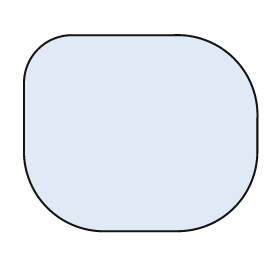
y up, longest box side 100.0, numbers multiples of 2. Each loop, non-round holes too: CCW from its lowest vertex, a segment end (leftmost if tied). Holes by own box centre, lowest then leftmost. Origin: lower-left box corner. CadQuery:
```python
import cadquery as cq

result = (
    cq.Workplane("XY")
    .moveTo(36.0, 0.0)
    .lineTo(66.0, 0.0)
    .threePointArc((90.0, 10.0), (100.0, 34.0))
    .lineTo(100.0, 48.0)
    .threePointArc((90.0, 74.0), (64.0, 84.0))
    .lineTo(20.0, 84.0)
    .threePointArc((6.0, 78.0), (0.0, 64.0))
    .lineTo(0.0, 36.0)
    .threePointArc((10.0, 10.0), (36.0, 0.0))
    .close()
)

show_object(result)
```